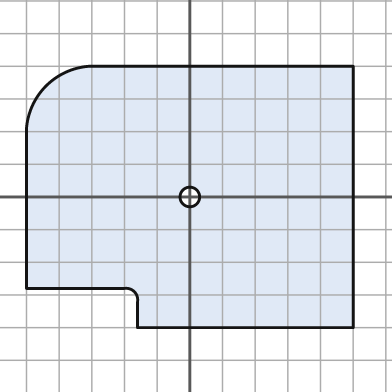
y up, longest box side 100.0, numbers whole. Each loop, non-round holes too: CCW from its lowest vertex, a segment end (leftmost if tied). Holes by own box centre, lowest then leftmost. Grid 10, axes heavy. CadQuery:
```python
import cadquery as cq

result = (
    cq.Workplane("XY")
    .moveTo(-16.0, -40.0)
    .lineTo(50.0, -40.0)
    .lineTo(50.0, 40.0)
    .lineTo(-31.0, 40.0)
    .threePointArc((-44.0, 34.0), (-50.0, 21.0))
    .lineTo(-50.0, -28.0)
    .lineTo(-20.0, -28.0)
    .threePointArc((-17.0, -29.0), (-16.0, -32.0))
    .close()
    .moveTo(0.0, 0.0)
    .circle(3.0)
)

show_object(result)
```